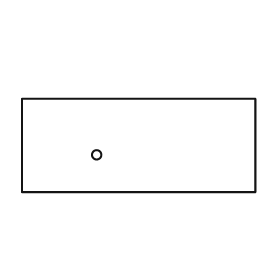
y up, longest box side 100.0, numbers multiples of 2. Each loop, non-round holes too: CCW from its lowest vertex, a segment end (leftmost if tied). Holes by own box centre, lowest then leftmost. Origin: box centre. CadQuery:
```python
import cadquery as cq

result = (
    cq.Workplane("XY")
    .moveTo(-50.0, -20.0)
    .lineTo(50.0, -20.0)
    .lineTo(50.0, 20.0)
    .lineTo(-50.0, 20.0)
    .close()
    .moveTo(-18.0, -4.0)
    .circle(2.0)
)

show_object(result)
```